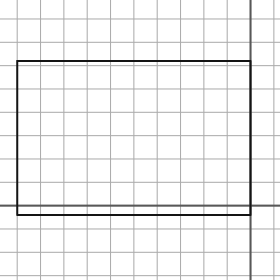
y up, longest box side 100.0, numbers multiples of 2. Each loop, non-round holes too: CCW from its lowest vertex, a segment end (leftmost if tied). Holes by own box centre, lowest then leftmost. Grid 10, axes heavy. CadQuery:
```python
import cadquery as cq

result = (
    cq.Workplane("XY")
    .moveTo(-100.0, -4.0)
    .lineTo(0.0, -4.0)
    .lineTo(0.0, 62.0)
    .lineTo(-100.0, 62.0)
    .close()
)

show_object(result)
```